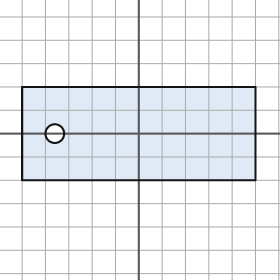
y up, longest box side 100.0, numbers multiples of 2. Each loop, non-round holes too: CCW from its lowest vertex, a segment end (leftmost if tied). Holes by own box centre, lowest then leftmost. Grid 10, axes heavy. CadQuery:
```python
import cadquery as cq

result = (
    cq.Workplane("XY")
    .moveTo(-50.0, -20.0)
    .lineTo(50.0, -20.0)
    .lineTo(50.0, 20.0)
    .lineTo(-50.0, 20.0)
    .close()
    .moveTo(-36.0, 0.0)
    .circle(4.0)
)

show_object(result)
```